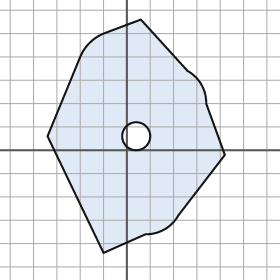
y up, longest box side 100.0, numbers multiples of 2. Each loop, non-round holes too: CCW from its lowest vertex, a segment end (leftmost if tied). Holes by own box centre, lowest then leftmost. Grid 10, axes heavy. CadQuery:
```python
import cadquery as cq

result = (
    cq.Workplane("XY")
    .moveTo(-10.0, -44.0)
    .lineTo(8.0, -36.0)
    .threePointArc((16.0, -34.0), (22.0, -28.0))
    .lineTo(42.0, -2.0)
    .lineTo(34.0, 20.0)
    .threePointArc((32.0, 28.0), (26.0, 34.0))
    .lineTo(6.0, 56.0)
    .lineTo(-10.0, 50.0)
    .threePointArc((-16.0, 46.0), (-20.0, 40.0))
    .lineTo(-34.0, 6.0)
    .close()
    .moveTo(4.0, 6.0)
    .circle(6.0)
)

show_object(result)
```